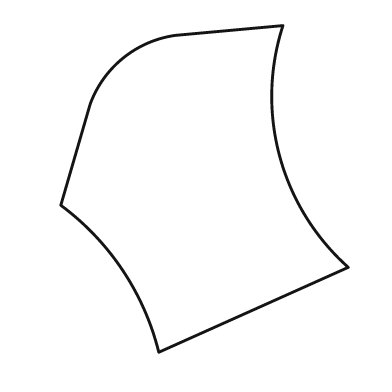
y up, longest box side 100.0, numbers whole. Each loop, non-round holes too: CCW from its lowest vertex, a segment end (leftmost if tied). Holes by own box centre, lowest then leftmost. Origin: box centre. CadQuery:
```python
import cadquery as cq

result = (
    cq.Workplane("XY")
    .moveTo(-14.0, -50.0)
    .lineTo(44.0, -24.0)
    .threePointArc((23.0, 10.0), (24.0, 50.0))
    .lineTo(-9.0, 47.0)
    .threePointArc((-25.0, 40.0), (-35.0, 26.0))
    .lineTo(-44.0, -5.0)
    .threePointArc((-25.0, -25.0), (-14.0, -50.0))
    .close()
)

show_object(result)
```